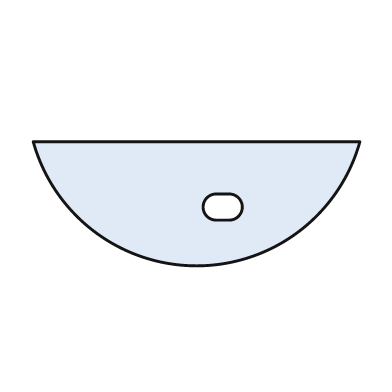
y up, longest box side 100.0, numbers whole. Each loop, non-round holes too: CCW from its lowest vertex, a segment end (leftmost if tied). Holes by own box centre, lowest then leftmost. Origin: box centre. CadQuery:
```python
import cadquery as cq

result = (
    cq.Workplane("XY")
    .moveTo(-50.0, 19.0)
    .threePointArc((0.0, -19.0), (50.0, 19.0))
    .close()
    .moveTo(6.0, -5.0)
    .lineTo(10.0, -5.0)
    .threePointArc((14.0, -1.0), (10.0, 3.0))
    .lineTo(6.0, 3.0)
    .threePointArc((2.0, -1.0), (6.0, -5.0))
    .close()
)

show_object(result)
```